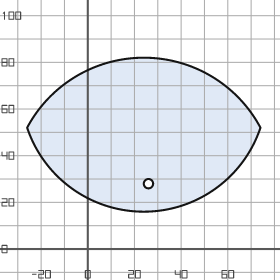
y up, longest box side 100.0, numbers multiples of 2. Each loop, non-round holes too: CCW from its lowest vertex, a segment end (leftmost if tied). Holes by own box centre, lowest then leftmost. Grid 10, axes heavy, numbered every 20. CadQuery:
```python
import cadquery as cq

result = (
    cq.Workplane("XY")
    .moveTo(-26.0, 52.0)
    .threePointArc((24.0, 16.0), (74.0, 52.0))
    .threePointArc((24.0, 82.0), (-26.0, 52.0))
    .close()
    .moveTo(26.0, 28.0)
    .circle(2.0)
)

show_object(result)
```